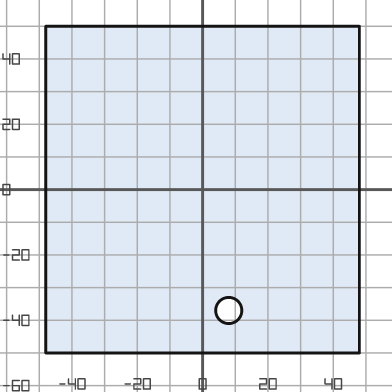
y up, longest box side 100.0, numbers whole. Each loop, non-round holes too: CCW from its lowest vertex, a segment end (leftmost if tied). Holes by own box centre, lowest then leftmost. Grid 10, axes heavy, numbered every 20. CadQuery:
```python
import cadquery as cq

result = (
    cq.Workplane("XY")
    .moveTo(-48.0, -50.0)
    .lineTo(48.0, -50.0)
    .lineTo(48.0, 50.0)
    .lineTo(-48.0, 50.0)
    .close()
    .moveTo(8.0, -37.0)
    .circle(4.0)
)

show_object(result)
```